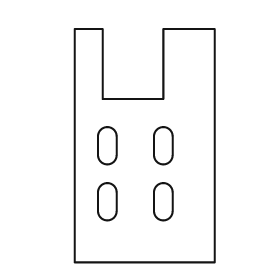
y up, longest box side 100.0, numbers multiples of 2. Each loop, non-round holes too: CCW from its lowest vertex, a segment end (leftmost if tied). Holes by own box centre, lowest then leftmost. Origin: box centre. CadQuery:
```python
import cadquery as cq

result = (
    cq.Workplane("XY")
    .moveTo(-30.0, -50.0)
    .lineTo(30.0, -50.0)
    .lineTo(30.0, 50.0)
    .lineTo(8.0, 50.0)
    .lineTo(8.0, 20.0)
    .lineTo(-18.0, 20.0)
    .lineTo(-18.0, 50.0)
    .lineTo(-30.0, 50.0)
    .close()
    .moveTo(-20.0, -28.0)
    .threePointArc((-16.0, -32.0), (-12.0, -28.0))
    .lineTo(-12.0, -20.0)
    .threePointArc((-16.0, -16.0), (-20.0, -20.0))
    .close()
    .moveTo(4.0, -28.0)
    .threePointArc((8.0, -32.0), (12.0, -28.0))
    .lineTo(12.0, -20.0)
    .threePointArc((8.0, -16.0), (4.0, -20.0))
    .close()
    .moveTo(-20.0, -4.0)
    .threePointArc((-16.0, -8.0), (-12.0, -4.0))
    .lineTo(-12.0, 4.0)
    .threePointArc((-16.0, 8.0), (-20.0, 4.0))
    .close()
    .moveTo(4.0, -4.0)
    .threePointArc((8.0, -8.0), (12.0, -4.0))
    .lineTo(12.0, 4.0)
    .threePointArc((8.0, 8.0), (4.0, 4.0))
    .close()
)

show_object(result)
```